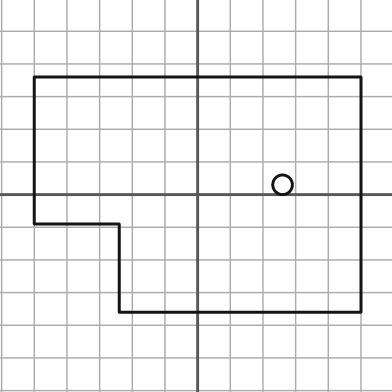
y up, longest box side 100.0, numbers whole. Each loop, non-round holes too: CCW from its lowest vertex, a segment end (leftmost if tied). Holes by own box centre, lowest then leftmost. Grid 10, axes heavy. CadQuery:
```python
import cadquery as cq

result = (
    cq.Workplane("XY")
    .moveTo(-24.0, -36.0)
    .lineTo(50.0, -36.0)
    .lineTo(50.0, 36.0)
    .lineTo(-50.0, 36.0)
    .lineTo(-50.0, -9.0)
    .lineTo(-24.0, -9.0)
    .close()
    .moveTo(26.0, 3.0)
    .circle(3.0)
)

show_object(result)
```